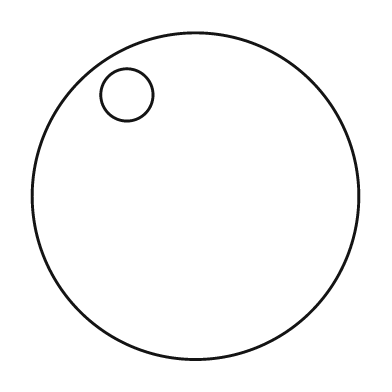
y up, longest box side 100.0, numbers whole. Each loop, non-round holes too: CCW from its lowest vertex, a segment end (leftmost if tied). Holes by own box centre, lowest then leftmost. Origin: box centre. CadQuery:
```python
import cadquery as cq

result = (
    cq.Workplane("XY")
    .moveTo(0.0, 0.0)
    .circle(50.0)
    .moveTo(-21.0, 31.0)
    .circle(8.0)
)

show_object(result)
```